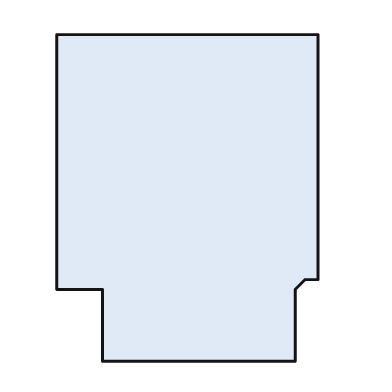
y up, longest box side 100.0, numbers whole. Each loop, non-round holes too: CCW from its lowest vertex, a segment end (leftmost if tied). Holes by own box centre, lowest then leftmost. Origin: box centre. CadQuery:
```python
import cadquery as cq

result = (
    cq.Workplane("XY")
    .moveTo(-26.0, -50.0)
    .lineTo(33.0, -50.0)
    .lineTo(33.0, -28.0)
    .lineTo(36.0, -25.0)
    .lineTo(40.0, -25.0)
    .lineTo(40.0, 50.0)
    .lineTo(-40.0, 50.0)
    .lineTo(-40.0, -28.0)
    .lineTo(-26.0, -28.0)
    .close()
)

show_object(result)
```